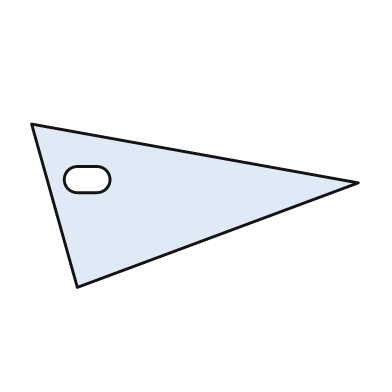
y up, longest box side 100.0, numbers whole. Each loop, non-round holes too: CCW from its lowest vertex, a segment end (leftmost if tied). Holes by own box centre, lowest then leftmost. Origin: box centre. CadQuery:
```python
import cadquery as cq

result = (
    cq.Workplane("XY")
    .moveTo(-36.0, -25.0)
    .lineTo(50.0, 7.0)
    .lineTo(-50.0, 25.0)
    .close()
    .moveTo(-36.0, 4.0)
    .lineTo(-30.0, 4.0)
    .threePointArc((-26.0, 8.0), (-30.0, 12.0))
    .lineTo(-36.0, 12.0)
    .threePointArc((-40.0, 8.0), (-36.0, 4.0))
    .close()
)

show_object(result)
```